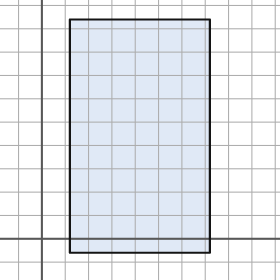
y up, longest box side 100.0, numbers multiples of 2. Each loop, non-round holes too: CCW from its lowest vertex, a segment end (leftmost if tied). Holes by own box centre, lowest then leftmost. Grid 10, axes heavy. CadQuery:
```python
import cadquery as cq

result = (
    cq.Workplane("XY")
    .moveTo(12.0, -6.0)
    .lineTo(72.0, -6.0)
    .lineTo(72.0, 94.0)
    .lineTo(12.0, 94.0)
    .close()
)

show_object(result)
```